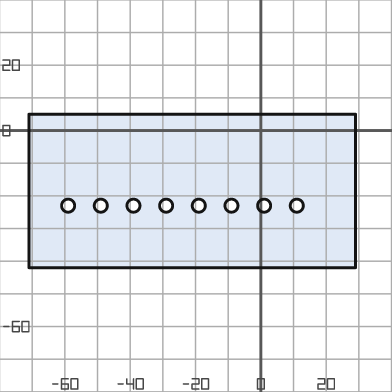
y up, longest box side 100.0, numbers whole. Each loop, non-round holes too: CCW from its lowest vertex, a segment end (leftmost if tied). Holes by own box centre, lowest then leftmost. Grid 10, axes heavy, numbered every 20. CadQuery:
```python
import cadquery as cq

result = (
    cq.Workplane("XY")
    .moveTo(-71.0, -42.0)
    .lineTo(29.0, -42.0)
    .lineTo(29.0, 5.0)
    .lineTo(-71.0, 5.0)
    .close()
    .moveTo(-59.0, -23.0)
    .circle(2.0)
    .moveTo(-49.0, -23.0)
    .circle(2.0)
    .moveTo(-39.0, -23.0)
    .circle(2.0)
    .moveTo(-29.0, -23.0)
    .circle(2.0)
    .moveTo(-19.0, -23.0)
    .circle(2.0)
    .moveTo(-9.0, -23.0)
    .circle(2.0)
    .moveTo(1.0, -23.0)
    .circle(2.0)
    .moveTo(11.0, -23.0)
    .circle(2.0)
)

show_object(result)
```